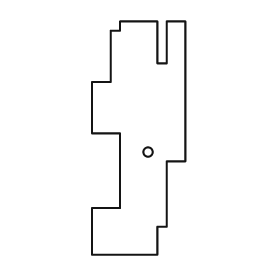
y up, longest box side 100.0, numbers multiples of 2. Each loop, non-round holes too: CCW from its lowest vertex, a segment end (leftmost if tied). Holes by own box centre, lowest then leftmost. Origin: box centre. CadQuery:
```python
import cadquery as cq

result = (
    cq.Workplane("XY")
    .moveTo(-20.0, -50.0)
    .lineTo(8.0, -50.0)
    .lineTo(8.0, -38.0)
    .lineTo(12.0, -38.0)
    .lineTo(12.0, -10.0)
    .lineTo(20.0, -10.0)
    .lineTo(20.0, 50.0)
    .lineTo(12.0, 50.0)
    .lineTo(12.0, 32.0)
    .lineTo(8.0, 32.0)
    .lineTo(8.0, 50.0)
    .lineTo(-8.0, 50.0)
    .lineTo(-8.0, 46.0)
    .lineTo(-12.0, 46.0)
    .lineTo(-12.0, 24.0)
    .lineTo(-20.0, 24.0)
    .lineTo(-20.0, 2.0)
    .lineTo(-8.0, 2.0)
    .lineTo(-8.0, -30.0)
    .lineTo(-20.0, -30.0)
    .close()
    .moveTo(4.0, -6.0)
    .circle(2.0)
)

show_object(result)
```